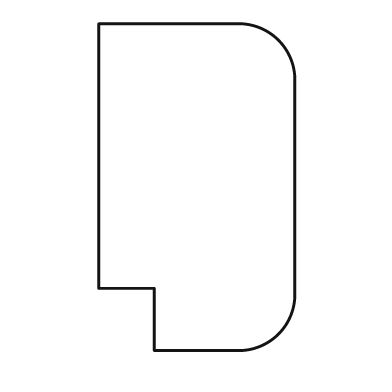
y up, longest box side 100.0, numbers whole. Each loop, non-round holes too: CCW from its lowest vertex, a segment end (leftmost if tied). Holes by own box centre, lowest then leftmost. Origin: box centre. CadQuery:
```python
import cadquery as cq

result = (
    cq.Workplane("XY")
    .moveTo(-13.0, -50.0)
    .lineTo(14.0, -50.0)
    .threePointArc((25.0, -45.0), (30.0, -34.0))
    .lineTo(30.0, 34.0)
    .threePointArc((25.0, 45.0), (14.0, 50.0))
    .lineTo(-30.0, 50.0)
    .lineTo(-30.0, -31.0)
    .lineTo(-13.0, -31.0)
    .close()
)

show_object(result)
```